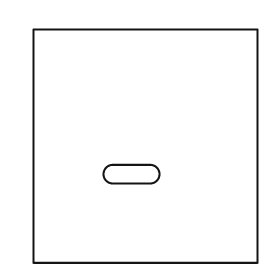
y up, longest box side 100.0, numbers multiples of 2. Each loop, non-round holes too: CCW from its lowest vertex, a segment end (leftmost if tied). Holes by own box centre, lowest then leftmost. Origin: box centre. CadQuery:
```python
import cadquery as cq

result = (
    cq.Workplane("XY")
    .moveTo(-48.0, -50.0)
    .lineTo(48.0, -50.0)
    .lineTo(48.0, 50.0)
    .lineTo(-48.0, 50.0)
    .close()
    .moveTo(-14.0, -16.0)
    .lineTo(2.0, -16.0)
    .threePointArc((6.0, -12.0), (2.0, -8.0))
    .lineTo(-14.0, -8.0)
    .threePointArc((-18.0, -12.0), (-14.0, -16.0))
    .close()
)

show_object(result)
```